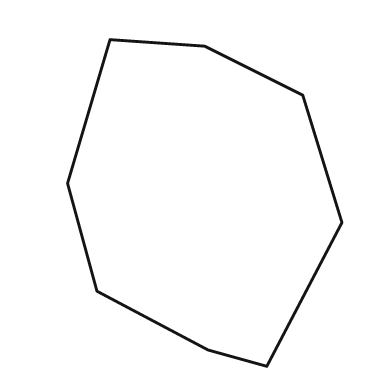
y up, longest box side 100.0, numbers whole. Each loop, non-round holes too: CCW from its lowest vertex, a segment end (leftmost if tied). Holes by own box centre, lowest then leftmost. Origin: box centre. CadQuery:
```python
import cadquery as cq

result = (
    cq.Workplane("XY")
    .moveTo(19.0, -50.0)
    .lineTo(42.0, -6.0)
    .lineTo(30.0, 33.0)
    .lineTo(0.0, 48.0)
    .lineTo(-29.0, 50.0)
    .lineTo(-42.0, 6.0)
    .lineTo(-33.0, -27.0)
    .lineTo(1.0, -45.0)
    .close()
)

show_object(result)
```